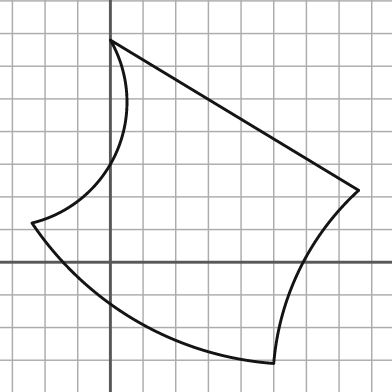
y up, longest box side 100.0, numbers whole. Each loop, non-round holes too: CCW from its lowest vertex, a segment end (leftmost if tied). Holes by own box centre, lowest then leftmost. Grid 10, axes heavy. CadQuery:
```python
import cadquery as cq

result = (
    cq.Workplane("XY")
    .moveTo(50.0, -31.0)
    .threePointArc((58.0, -2.0), (76.0, 22.0))
    .lineTo(0.0, 68.0)
    .threePointArc((2.0, 34.0), (-24.0, 12.0))
    .threePointArc((8.0, -18.0), (50.0, -31.0))
    .close()
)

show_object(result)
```